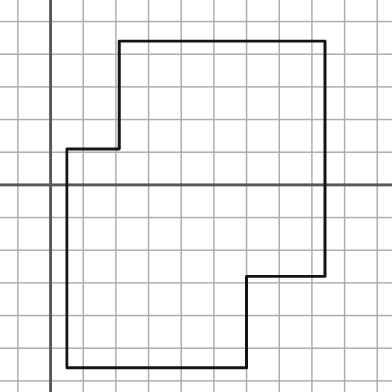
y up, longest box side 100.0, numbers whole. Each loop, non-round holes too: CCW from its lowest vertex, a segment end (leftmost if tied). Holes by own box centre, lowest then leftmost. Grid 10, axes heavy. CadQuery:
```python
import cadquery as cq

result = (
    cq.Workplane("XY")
    .moveTo(5.0, -56.0)
    .lineTo(60.0, -56.0)
    .lineTo(60.0, -28.0)
    .lineTo(84.0, -28.0)
    .lineTo(84.0, 44.0)
    .lineTo(21.0, 44.0)
    .lineTo(21.0, 11.0)
    .lineTo(5.0, 11.0)
    .close()
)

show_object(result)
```